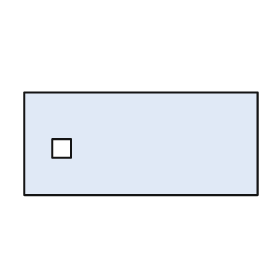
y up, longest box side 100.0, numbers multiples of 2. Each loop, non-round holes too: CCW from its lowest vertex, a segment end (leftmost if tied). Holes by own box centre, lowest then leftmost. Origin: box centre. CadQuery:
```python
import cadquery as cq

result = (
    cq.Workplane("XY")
    .moveTo(-50.0, -22.0)
    .lineTo(50.0, -22.0)
    .lineTo(50.0, 22.0)
    .lineTo(-50.0, 22.0)
    .close()
    .moveTo(-38.0, -6.0)
    .lineTo(-30.0, -6.0)
    .lineTo(-30.0, 2.0)
    .lineTo(-38.0, 2.0)
    .close()
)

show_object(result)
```